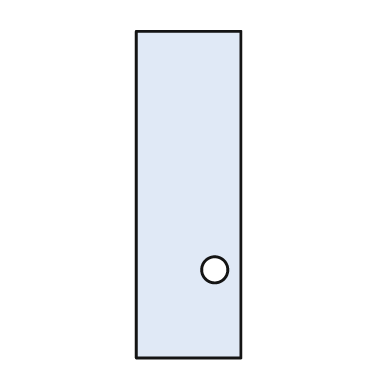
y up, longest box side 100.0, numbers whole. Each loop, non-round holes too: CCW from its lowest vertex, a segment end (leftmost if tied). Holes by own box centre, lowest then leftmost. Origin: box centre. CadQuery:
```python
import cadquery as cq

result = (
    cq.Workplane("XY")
    .moveTo(-16.0, -50.0)
    .lineTo(16.0, -50.0)
    .lineTo(16.0, 50.0)
    .lineTo(-16.0, 50.0)
    .close()
    .moveTo(8.0, -23.0)
    .circle(4.0)
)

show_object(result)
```